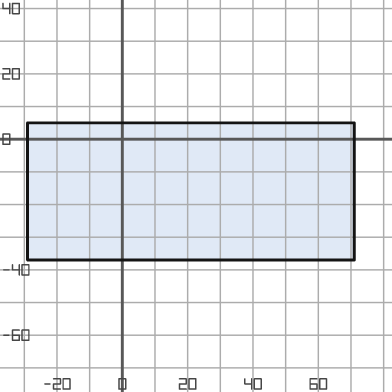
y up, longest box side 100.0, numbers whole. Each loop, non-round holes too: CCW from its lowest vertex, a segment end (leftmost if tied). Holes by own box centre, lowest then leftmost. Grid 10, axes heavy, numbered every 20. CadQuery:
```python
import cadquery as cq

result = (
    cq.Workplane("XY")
    .moveTo(-29.0, -37.0)
    .lineTo(71.0, -37.0)
    .lineTo(71.0, 5.0)
    .lineTo(-29.0, 5.0)
    .close()
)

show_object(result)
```